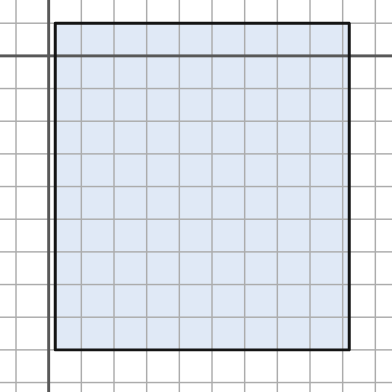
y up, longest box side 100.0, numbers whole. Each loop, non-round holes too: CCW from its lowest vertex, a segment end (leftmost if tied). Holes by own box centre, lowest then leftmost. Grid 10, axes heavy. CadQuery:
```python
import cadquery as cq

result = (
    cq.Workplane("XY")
    .moveTo(2.0, -90.0)
    .lineTo(92.0, -90.0)
    .lineTo(92.0, 10.0)
    .lineTo(2.0, 10.0)
    .close()
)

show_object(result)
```